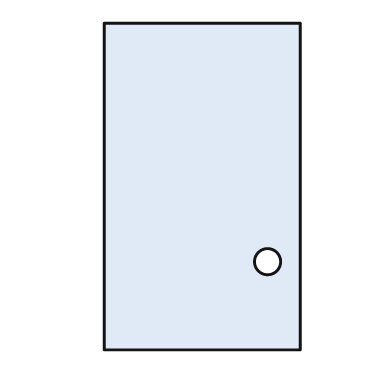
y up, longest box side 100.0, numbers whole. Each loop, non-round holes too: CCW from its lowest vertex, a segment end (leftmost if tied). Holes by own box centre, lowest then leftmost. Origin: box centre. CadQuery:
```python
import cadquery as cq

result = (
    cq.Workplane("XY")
    .moveTo(-30.0, -50.0)
    .lineTo(30.0, -50.0)
    .lineTo(30.0, 50.0)
    .lineTo(-30.0, 50.0)
    .close()
    .moveTo(20.0, -23.0)
    .circle(4.0)
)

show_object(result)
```